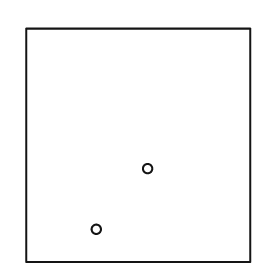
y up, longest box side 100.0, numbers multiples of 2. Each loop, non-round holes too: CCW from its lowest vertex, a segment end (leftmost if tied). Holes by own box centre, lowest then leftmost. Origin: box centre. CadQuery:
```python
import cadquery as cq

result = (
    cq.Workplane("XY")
    .moveTo(-48.0, -50.0)
    .lineTo(48.0, -50.0)
    .lineTo(48.0, 50.0)
    .lineTo(-48.0, 50.0)
    .close()
    .moveTo(-18.0, -36.0)
    .circle(2.0)
    .moveTo(4.0, -10.0)
    .circle(2.0)
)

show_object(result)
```